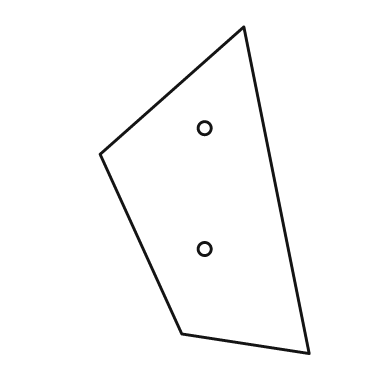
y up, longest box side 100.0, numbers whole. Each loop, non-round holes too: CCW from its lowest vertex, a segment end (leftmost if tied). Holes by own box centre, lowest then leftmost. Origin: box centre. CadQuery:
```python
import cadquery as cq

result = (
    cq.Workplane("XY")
    .moveTo(32.0, -50.0)
    .lineTo(12.0, 50.0)
    .lineTo(-32.0, 11.0)
    .lineTo(-7.0, -44.0)
    .close()
    .moveTo(0.0, -18.0)
    .circle(2.0)
    .moveTo(0.0, 19.0)
    .circle(2.0)
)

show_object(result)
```